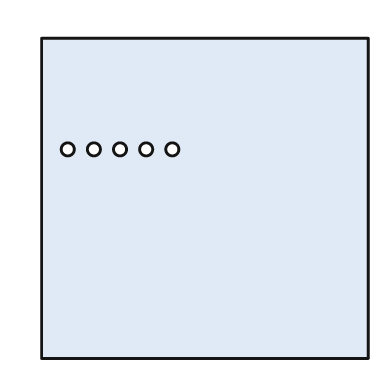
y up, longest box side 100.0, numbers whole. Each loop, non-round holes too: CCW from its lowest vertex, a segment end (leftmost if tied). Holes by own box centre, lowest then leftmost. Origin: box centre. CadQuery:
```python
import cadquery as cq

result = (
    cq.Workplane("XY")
    .moveTo(-50.0, -49.0)
    .lineTo(50.0, -49.0)
    .lineTo(50.0, 49.0)
    .lineTo(-50.0, 49.0)
    .close()
    .moveTo(-42.0, 15.0)
    .circle(2.0)
    .moveTo(-34.0, 15.0)
    .circle(2.0)
    .moveTo(-26.0, 15.0)
    .circle(2.0)
    .moveTo(-18.0, 15.0)
    .circle(2.0)
    .moveTo(-10.0, 15.0)
    .circle(2.0)
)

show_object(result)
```